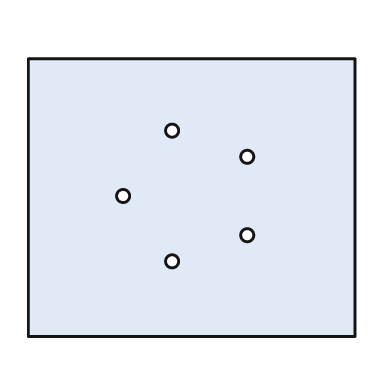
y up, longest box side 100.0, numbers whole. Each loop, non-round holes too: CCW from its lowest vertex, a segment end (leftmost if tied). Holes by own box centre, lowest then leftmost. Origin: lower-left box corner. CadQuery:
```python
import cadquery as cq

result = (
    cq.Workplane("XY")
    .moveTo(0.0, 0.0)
    .lineTo(100.0, 0.0)
    .lineTo(100.0, 85.0)
    .lineTo(0.0, 85.0)
    .close()
    .moveTo(44.0, 23.0)
    .circle(2.0)
    .moveTo(67.0, 31.0)
    .circle(2.0)
    .moveTo(29.0, 43.0)
    .circle(2.0)
    .moveTo(67.0, 55.0)
    .circle(2.0)
    .moveTo(44.0, 63.0)
    .circle(2.0)
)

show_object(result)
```